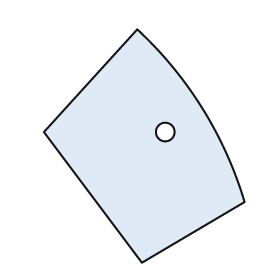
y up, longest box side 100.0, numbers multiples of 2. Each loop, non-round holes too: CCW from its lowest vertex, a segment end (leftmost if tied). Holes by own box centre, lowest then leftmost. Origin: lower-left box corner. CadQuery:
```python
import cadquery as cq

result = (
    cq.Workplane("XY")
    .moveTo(42.0, 0.0)
    .lineTo(86.0, 26.0)
    .threePointArc((68.0, 66.0), (40.0, 100.0))
    .lineTo(0.0, 56.0)
    .close()
    .moveTo(52.0, 56.0)
    .circle(4.0)
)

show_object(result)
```